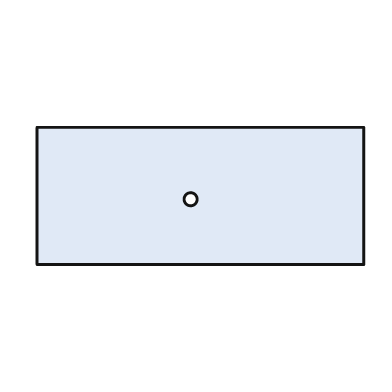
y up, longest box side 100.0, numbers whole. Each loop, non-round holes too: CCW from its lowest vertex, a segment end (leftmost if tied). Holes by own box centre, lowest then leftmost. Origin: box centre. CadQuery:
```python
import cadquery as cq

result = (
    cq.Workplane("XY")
    .moveTo(-50.0, -21.0)
    .lineTo(50.0, -21.0)
    .lineTo(50.0, 21.0)
    .lineTo(-50.0, 21.0)
    .close()
    .moveTo(-3.0, -1.0)
    .circle(2.0)
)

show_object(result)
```